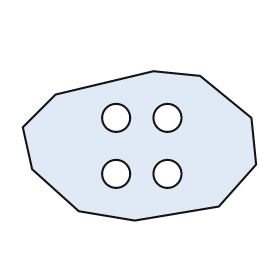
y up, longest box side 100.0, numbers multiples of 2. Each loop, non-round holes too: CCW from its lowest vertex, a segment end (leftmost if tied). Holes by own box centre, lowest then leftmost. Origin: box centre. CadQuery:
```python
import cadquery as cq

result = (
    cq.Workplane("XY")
    .moveTo(-2.0, -32.0)
    .lineTo(34.0, -26.0)
    .lineTo(50.0, -8.0)
    .lineTo(48.0, 12.0)
    .lineTo(26.0, 30.0)
    .lineTo(6.0, 32.0)
    .lineTo(-36.0, 22.0)
    .lineTo(-50.0, 8.0)
    .lineTo(-46.0, -10.0)
    .lineTo(-26.0, -28.0)
    .close()
    .moveTo(-10.0, -12.0)
    .circle(6.0)
    .moveTo(12.0, -12.0)
    .circle(6.0)
    .moveTo(-10.0, 12.0)
    .circle(6.0)
    .moveTo(12.0, 12.0)
    .circle(6.0)
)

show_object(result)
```